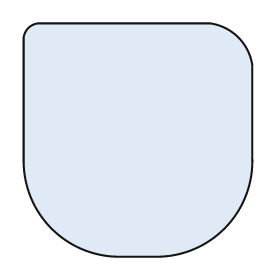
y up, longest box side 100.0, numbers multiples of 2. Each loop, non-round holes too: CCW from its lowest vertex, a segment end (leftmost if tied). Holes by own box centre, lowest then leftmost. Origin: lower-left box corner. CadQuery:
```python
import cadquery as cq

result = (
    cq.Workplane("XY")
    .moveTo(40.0, 0.0)
    .lineTo(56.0, 0.0)
    .threePointArc((86.0, 12.0), (98.0, 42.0))
    .lineTo(98.0, 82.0)
    .threePointArc((92.0, 94.0), (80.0, 100.0))
    .lineTo(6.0, 100.0)
    .threePointArc((2.0, 98.0), (0.0, 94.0))
    .lineTo(0.0, 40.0)
    .threePointArc((12.0, 12.0), (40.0, 0.0))
    .close()
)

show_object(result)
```